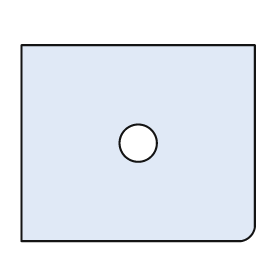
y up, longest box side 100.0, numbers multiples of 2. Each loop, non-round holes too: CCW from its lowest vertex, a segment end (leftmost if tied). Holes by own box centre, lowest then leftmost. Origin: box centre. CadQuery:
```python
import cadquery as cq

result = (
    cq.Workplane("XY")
    .moveTo(-50.0, -42.0)
    .lineTo(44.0, -42.0)
    .threePointArc((48.0, -40.0), (50.0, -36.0))
    .lineTo(50.0, 42.0)
    .lineTo(-50.0, 42.0)
    .close()
    .moveTo(0.0, 0.0)
    .circle(8.0)
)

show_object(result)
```